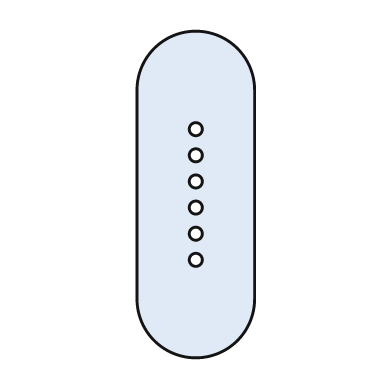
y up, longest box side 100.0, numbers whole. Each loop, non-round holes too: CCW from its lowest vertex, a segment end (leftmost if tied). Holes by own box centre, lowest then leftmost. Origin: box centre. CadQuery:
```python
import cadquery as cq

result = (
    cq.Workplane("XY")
    .moveTo(-18.0, -32.0)
    .threePointArc((0.0, -50.0), (18.0, -32.0))
    .lineTo(18.0, 32.0)
    .threePointArc((0.0, 50.0), (-18.0, 32.0))
    .close()
    .moveTo(0.0, -20.0)
    .circle(2.0)
    .moveTo(0.0, -12.0)
    .circle(2.0)
    .moveTo(0.0, -4.0)
    .circle(2.0)
    .moveTo(0.0, 4.0)
    .circle(2.0)
    .moveTo(0.0, 12.0)
    .circle(2.0)
    .moveTo(0.0, 20.0)
    .circle(2.0)
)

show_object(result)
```